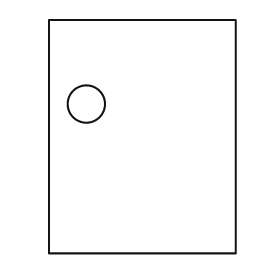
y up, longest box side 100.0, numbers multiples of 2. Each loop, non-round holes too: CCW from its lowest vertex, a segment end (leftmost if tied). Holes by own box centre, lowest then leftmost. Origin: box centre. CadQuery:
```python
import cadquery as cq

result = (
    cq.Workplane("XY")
    .moveTo(-40.0, -50.0)
    .lineTo(40.0, -50.0)
    .lineTo(40.0, 50.0)
    .lineTo(-40.0, 50.0)
    .close()
    .moveTo(-24.0, 14.0)
    .circle(8.0)
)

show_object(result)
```